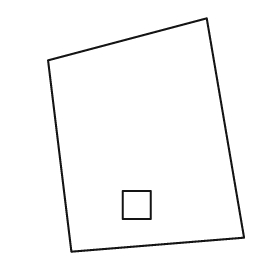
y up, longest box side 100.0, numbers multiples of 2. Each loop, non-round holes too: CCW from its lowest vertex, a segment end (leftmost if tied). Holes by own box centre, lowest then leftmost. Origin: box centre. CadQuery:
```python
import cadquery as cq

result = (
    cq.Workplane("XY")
    .moveTo(-32.0, -50.0)
    .lineTo(42.0, -44.0)
    .lineTo(26.0, 50.0)
    .lineTo(-42.0, 32.0)
    .close()
    .moveTo(-10.0, -36.0)
    .lineTo(2.0, -36.0)
    .lineTo(2.0, -24.0)
    .lineTo(-10.0, -24.0)
    .close()
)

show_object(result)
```